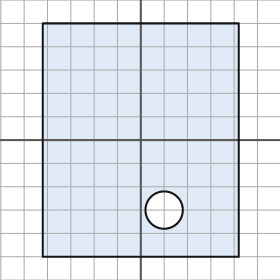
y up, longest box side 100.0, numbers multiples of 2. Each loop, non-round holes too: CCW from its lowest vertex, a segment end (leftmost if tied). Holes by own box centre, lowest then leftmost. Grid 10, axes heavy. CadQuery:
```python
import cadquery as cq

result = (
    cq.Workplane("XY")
    .moveTo(-42.0, -50.0)
    .lineTo(42.0, -50.0)
    .lineTo(42.0, 50.0)
    .lineTo(-42.0, 50.0)
    .close()
    .moveTo(10.0, -30.0)
    .circle(8.0)
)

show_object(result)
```